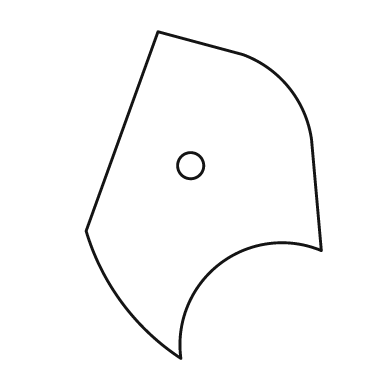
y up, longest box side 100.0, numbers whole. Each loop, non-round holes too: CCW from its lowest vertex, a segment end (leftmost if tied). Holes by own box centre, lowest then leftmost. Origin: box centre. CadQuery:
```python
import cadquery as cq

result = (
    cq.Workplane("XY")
    .moveTo(-7.0, -50.0)
    .threePointArc((5.0, -21.0), (36.0, -17.0))
    .lineTo(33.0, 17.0)
    .threePointArc((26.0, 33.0), (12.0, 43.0))
    .lineTo(-14.0, 50.0)
    .lineTo(-36.0, -11.0)
    .threePointArc((-25.0, -33.0), (-7.0, -50.0))
    .close()
    .moveTo(-4.0, 9.0)
    .circle(4.0)
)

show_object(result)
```